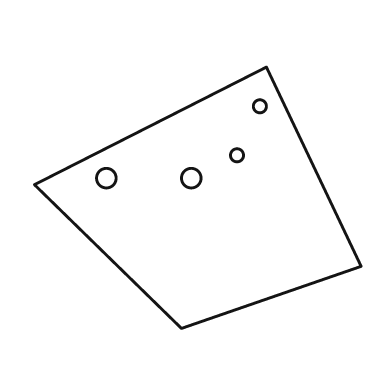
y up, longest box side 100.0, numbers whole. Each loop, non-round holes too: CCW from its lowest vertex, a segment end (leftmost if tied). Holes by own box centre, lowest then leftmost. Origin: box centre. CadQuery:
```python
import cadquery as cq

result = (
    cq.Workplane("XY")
    .moveTo(-5.0, -40.0)
    .lineTo(50.0, -21.0)
    .lineTo(21.0, 40.0)
    .lineTo(-50.0, 4.0)
    .close()
    .moveTo(-28.0, 6.0)
    .circle(3.0)
    .moveTo(-2.0, 6.0)
    .circle(3.0)
    .moveTo(12.0, 13.0)
    .circle(2.0)
    .moveTo(19.0, 28.0)
    .circle(2.0)
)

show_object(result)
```